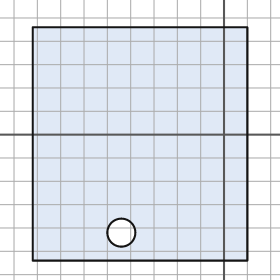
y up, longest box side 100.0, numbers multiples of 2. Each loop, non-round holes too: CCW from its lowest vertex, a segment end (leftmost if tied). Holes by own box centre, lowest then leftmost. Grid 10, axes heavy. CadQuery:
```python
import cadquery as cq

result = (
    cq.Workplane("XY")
    .moveTo(-82.0, -54.0)
    .lineTo(10.0, -54.0)
    .lineTo(10.0, 46.0)
    .lineTo(-82.0, 46.0)
    .close()
    .moveTo(-44.0, -42.0)
    .circle(6.0)
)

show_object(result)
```